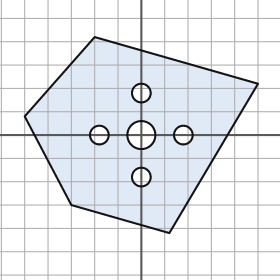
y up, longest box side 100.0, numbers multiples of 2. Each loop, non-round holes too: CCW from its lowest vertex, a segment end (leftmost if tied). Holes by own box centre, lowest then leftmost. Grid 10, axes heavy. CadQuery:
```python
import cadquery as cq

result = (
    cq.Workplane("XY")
    .moveTo(12.0, -42.0)
    .lineTo(50.0, 22.0)
    .lineTo(-20.0, 42.0)
    .lineTo(-50.0, 8.0)
    .lineTo(-30.0, -30.0)
    .close()
    .moveTo(0.0, -18.0)
    .circle(4.0)
    .moveTo(-18.0, 0.0)
    .circle(4.0)
    .moveTo(0.0, 0.0)
    .circle(6.0)
    .moveTo(18.0, 0.0)
    .circle(4.0)
    .moveTo(0.0, 18.0)
    .circle(4.0)
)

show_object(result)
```